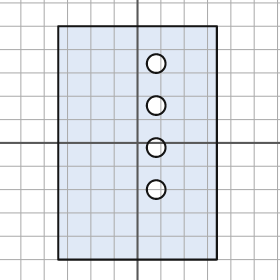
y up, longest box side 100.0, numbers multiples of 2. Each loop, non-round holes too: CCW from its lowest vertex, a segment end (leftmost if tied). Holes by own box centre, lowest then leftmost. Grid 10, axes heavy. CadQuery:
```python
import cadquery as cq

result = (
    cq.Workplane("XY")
    .moveTo(-34.0, -50.0)
    .lineTo(34.0, -50.0)
    .lineTo(34.0, 50.0)
    .lineTo(-34.0, 50.0)
    .close()
    .moveTo(8.0, -20.0)
    .circle(4.0)
    .moveTo(8.0, -2.0)
    .circle(4.0)
    .moveTo(8.0, 16.0)
    .circle(4.0)
    .moveTo(8.0, 34.0)
    .circle(4.0)
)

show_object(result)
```